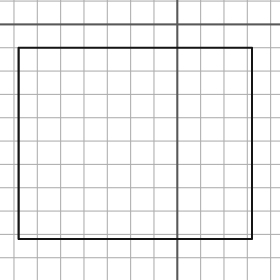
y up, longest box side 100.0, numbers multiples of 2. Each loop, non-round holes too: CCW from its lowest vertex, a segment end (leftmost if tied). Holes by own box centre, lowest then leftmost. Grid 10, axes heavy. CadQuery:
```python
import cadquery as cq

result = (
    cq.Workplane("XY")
    .moveTo(-68.0, -92.0)
    .lineTo(32.0, -92.0)
    .lineTo(32.0, -10.0)
    .lineTo(-68.0, -10.0)
    .close()
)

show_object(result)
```